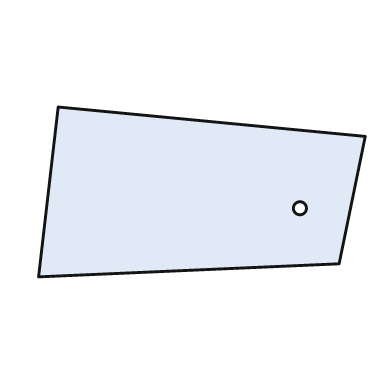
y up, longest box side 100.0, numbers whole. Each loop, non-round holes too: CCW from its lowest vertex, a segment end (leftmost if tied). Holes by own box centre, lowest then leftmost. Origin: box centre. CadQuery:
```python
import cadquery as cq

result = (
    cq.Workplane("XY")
    .moveTo(-50.0, -26.0)
    .lineTo(42.0, -22.0)
    .lineTo(50.0, 17.0)
    .lineTo(-44.0, 26.0)
    .close()
    .moveTo(30.0, -5.0)
    .circle(2.0)
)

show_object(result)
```